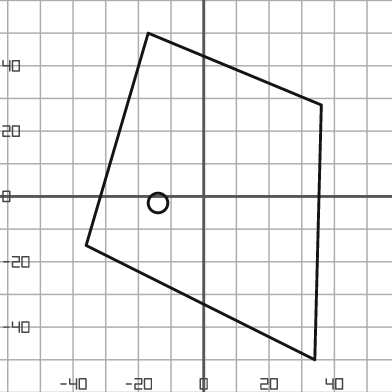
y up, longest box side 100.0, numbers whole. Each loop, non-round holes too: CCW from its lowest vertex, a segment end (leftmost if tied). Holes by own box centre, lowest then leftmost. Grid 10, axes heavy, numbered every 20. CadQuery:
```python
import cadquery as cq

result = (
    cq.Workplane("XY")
    .moveTo(34.0, -50.0)
    .lineTo(36.0, 28.0)
    .lineTo(-17.0, 50.0)
    .lineTo(-36.0, -15.0)
    .close()
    .moveTo(-14.0, -2.0)
    .circle(3.0)
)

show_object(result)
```